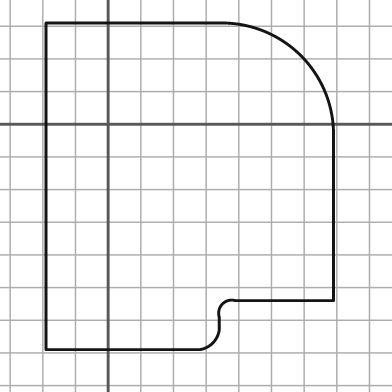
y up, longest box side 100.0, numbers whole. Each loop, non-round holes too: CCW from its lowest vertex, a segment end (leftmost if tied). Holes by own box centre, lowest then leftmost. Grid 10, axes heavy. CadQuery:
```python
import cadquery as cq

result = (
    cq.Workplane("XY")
    .moveTo(-19.0, -69.0)
    .lineTo(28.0, -69.0)
    .threePointArc((32.0, -67.0), (34.0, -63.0))
    .lineTo(34.0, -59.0)
    .threePointArc((35.0, -55.0), (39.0, -54.0))
    .lineTo(69.0, -54.0)
    .lineTo(69.0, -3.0)
    .threePointArc((59.0, 21.0), (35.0, 31.0))
    .lineTo(-19.0, 31.0)
    .close()
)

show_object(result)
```